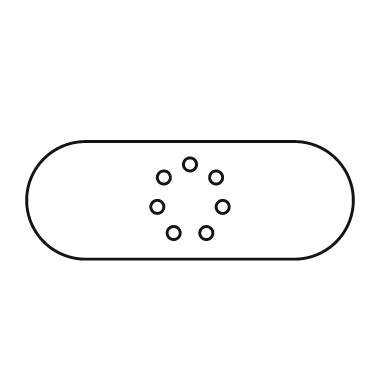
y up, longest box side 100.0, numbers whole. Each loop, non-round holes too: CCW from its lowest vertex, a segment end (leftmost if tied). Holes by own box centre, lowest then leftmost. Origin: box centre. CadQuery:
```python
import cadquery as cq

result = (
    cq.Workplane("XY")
    .moveTo(-32.0, -18.0)
    .lineTo(32.0, -18.0)
    .threePointArc((50.0, 0.0), (32.0, 18.0))
    .lineTo(-32.0, 18.0)
    .threePointArc((-50.0, 0.0), (-32.0, -18.0))
    .close()
    .moveTo(-5.0, -10.0)
    .circle(2.0)
    .moveTo(5.0, -10.0)
    .circle(2.0)
    .moveTo(-10.0, -2.0)
    .circle(2.0)
    .moveTo(10.0, -2.0)
    .circle(2.0)
    .moveTo(-8.0, 7.0)
    .circle(2.0)
    .moveTo(8.0, 7.0)
    .circle(2.0)
    .moveTo(0.0, 11.0)
    .circle(2.0)
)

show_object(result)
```